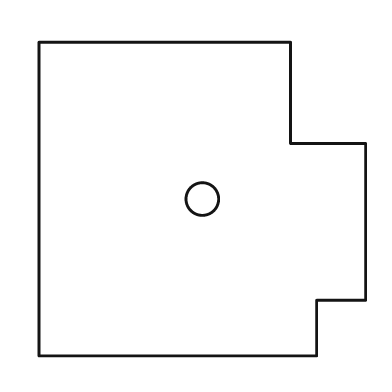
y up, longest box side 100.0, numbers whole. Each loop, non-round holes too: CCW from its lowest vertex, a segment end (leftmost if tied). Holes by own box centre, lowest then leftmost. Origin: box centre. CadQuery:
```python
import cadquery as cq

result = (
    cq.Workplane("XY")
    .moveTo(-50.0, -48.0)
    .lineTo(35.0, -48.0)
    .lineTo(35.0, -31.0)
    .lineTo(50.0, -31.0)
    .lineTo(50.0, 17.0)
    .lineTo(27.0, 17.0)
    .lineTo(27.0, 48.0)
    .lineTo(-50.0, 48.0)
    .close()
    .moveTo(0.0, 0.0)
    .circle(5.0)
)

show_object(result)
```